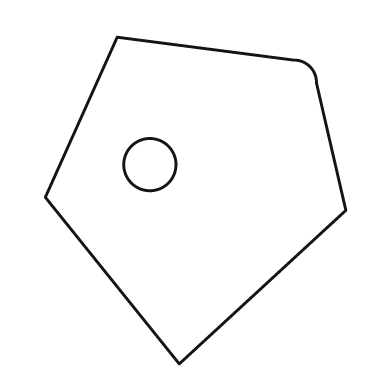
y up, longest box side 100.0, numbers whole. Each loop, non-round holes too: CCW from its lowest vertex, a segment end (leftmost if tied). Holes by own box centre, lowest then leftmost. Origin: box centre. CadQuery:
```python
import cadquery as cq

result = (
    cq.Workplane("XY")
    .moveTo(-5.0, -50.0)
    .lineTo(46.0, -3.0)
    .lineTo(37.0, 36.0)
    .threePointArc((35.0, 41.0), (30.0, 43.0))
    .lineTo(-24.0, 50.0)
    .lineTo(-46.0, 1.0)
    .close()
    .moveTo(-14.0, 11.0)
    .circle(8.0)
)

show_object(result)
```